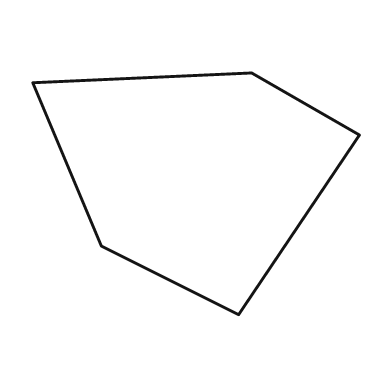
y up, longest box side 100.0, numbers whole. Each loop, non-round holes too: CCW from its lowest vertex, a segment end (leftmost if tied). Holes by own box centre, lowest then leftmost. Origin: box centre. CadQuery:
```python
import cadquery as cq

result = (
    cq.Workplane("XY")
    .moveTo(13.0, -37.0)
    .lineTo(50.0, 18.0)
    .lineTo(17.0, 37.0)
    .lineTo(-50.0, 34.0)
    .lineTo(-29.0, -16.0)
    .close()
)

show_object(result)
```